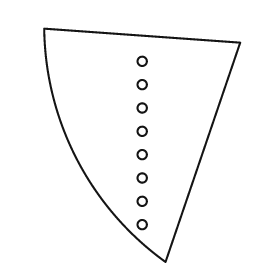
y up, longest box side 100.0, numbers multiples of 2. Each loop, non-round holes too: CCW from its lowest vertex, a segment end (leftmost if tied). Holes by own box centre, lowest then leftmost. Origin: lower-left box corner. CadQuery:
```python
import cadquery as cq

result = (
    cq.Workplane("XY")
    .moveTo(52.0, 0.0)
    .lineTo(84.0, 94.0)
    .lineTo(0.0, 100.0)
    .threePointArc((14.0, 44.0), (52.0, 0.0))
    .close()
    .moveTo(42.0, 16.0)
    .circle(2.0)
    .moveTo(42.0, 26.0)
    .circle(2.0)
    .moveTo(42.0, 36.0)
    .circle(2.0)
    .moveTo(42.0, 46.0)
    .circle(2.0)
    .moveTo(42.0, 56.0)
    .circle(2.0)
    .moveTo(42.0, 66.0)
    .circle(2.0)
    .moveTo(42.0, 76.0)
    .circle(2.0)
    .moveTo(42.0, 86.0)
    .circle(2.0)
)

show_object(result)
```